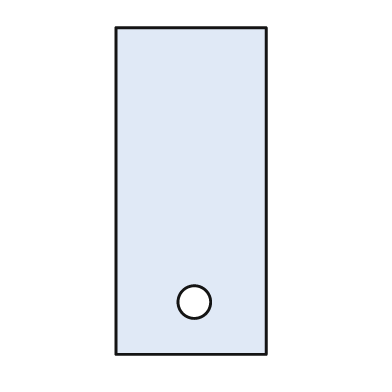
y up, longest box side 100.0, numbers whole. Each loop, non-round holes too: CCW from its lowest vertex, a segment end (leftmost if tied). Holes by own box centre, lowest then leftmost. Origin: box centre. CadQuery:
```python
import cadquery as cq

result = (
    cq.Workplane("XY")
    .moveTo(-23.0, -50.0)
    .lineTo(23.0, -50.0)
    .lineTo(23.0, 50.0)
    .lineTo(-23.0, 50.0)
    .close()
    .moveTo(1.0, -34.0)
    .circle(5.0)
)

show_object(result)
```